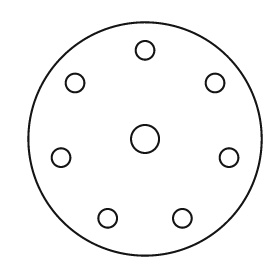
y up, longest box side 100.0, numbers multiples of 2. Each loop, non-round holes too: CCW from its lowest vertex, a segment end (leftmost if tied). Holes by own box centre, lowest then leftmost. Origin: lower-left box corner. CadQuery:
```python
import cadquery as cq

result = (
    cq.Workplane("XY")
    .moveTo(50.0, 50.0)
    .circle(50.0)
    .moveTo(34.0, 16.0)
    .circle(4.0)
    .moveTo(66.0, 16.0)
    .circle(4.0)
    .moveTo(14.0, 42.0)
    .circle(4.0)
    .moveTo(86.0, 42.0)
    .circle(4.0)
    .moveTo(50.0, 50.0)
    .circle(6.0)
    .moveTo(20.0, 74.0)
    .circle(4.0)
    .moveTo(80.0, 74.0)
    .circle(4.0)
    .moveTo(50.0, 88.0)
    .circle(4.0)
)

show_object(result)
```